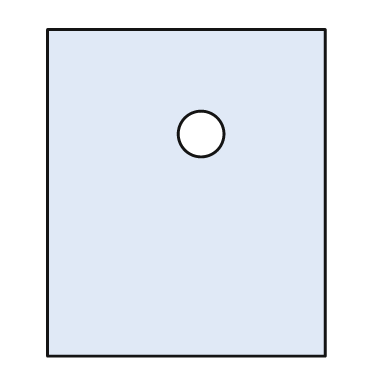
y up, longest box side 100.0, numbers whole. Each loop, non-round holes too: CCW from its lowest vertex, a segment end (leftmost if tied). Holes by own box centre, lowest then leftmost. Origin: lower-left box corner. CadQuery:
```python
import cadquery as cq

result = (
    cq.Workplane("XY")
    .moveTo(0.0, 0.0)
    .lineTo(85.0, 0.0)
    .lineTo(85.0, 100.0)
    .lineTo(0.0, 100.0)
    .close()
    .moveTo(47.0, 68.0)
    .circle(7.0)
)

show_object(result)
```